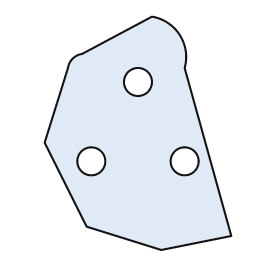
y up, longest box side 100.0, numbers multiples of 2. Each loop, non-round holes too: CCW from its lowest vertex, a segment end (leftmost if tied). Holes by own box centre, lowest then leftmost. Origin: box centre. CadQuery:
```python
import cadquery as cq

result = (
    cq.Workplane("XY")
    .moveTo(10.0, -50.0)
    .lineTo(40.0, -44.0)
    .lineTo(20.0, 28.0)
    .threePointArc((18.0, 42.0), (6.0, 50.0))
    .lineTo(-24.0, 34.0)
    .threePointArc((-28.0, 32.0), (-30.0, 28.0))
    .lineTo(-40.0, -4.0)
    .lineTo(-22.0, -40.0)
    .close()
    .moveTo(-20.0, -12.0)
    .circle(6.0)
    .moveTo(20.0, -12.0)
    .circle(6.0)
    .moveTo(0.0, 22.0)
    .circle(6.0)
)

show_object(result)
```